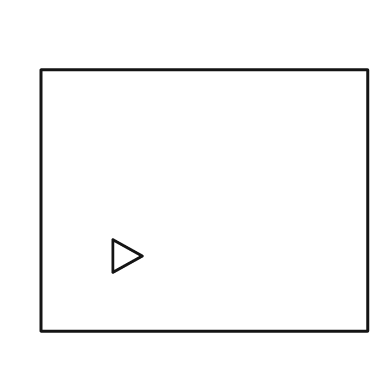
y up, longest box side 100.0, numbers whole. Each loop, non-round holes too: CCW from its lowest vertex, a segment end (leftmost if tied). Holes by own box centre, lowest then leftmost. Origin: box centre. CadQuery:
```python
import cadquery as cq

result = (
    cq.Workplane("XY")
    .moveTo(-50.0, -40.0)
    .lineTo(50.0, -40.0)
    .lineTo(50.0, 40.0)
    .lineTo(-50.0, 40.0)
    .close()
    .moveTo(-28.0, -22.0)
    .lineTo(-19.0, -17.0)
    .lineTo(-28.0, -12.0)
    .close()
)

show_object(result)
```